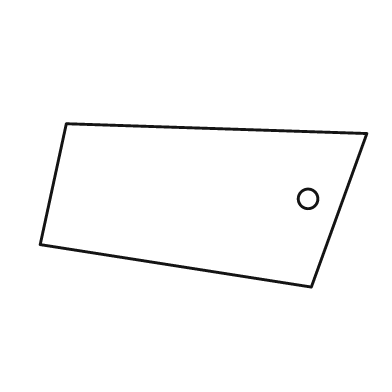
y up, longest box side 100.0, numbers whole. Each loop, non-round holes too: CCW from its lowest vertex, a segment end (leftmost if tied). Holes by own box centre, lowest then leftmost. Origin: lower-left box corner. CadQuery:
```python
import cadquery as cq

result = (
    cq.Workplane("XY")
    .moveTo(83.0, 0.0)
    .lineTo(100.0, 47.0)
    .lineTo(8.0, 50.0)
    .lineTo(0.0, 13.0)
    .close()
    .moveTo(82.0, 27.0)
    .circle(3.0)
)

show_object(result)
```